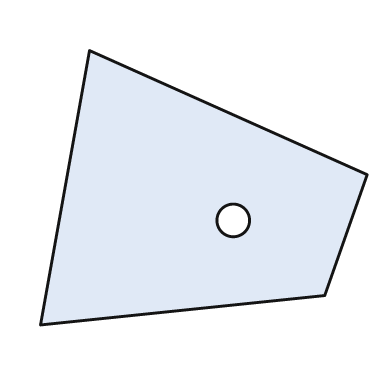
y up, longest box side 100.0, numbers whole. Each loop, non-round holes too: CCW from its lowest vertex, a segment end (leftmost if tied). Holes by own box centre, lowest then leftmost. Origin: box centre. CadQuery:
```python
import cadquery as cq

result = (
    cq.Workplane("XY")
    .moveTo(-50.0, -42.0)
    .lineTo(37.0, -33.0)
    .lineTo(50.0, 4.0)
    .lineTo(-35.0, 42.0)
    .close()
    .moveTo(9.0, -10.0)
    .circle(5.0)
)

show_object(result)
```